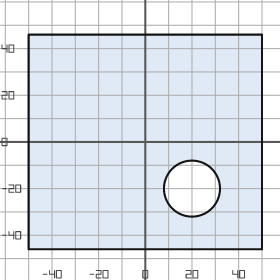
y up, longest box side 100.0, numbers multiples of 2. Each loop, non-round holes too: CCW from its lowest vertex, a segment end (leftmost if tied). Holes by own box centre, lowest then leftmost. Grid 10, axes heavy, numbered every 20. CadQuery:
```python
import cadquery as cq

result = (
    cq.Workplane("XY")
    .moveTo(-50.0, -46.0)
    .lineTo(50.0, -46.0)
    .lineTo(50.0, 46.0)
    .lineTo(-50.0, 46.0)
    .close()
    .moveTo(20.0, -20.0)
    .circle(12.0)
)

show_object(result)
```